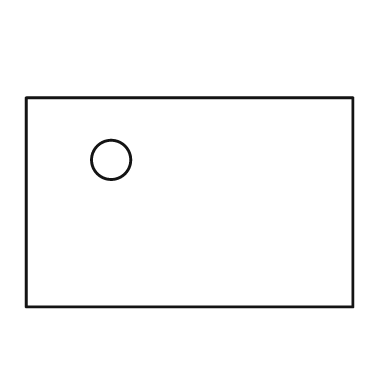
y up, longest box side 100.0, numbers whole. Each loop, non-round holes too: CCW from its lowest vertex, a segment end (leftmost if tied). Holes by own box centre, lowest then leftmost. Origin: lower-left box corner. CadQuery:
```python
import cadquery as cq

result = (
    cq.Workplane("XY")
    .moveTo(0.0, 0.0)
    .lineTo(100.0, 0.0)
    .lineTo(100.0, 64.0)
    .lineTo(0.0, 64.0)
    .close()
    .moveTo(26.0, 45.0)
    .circle(6.0)
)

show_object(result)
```